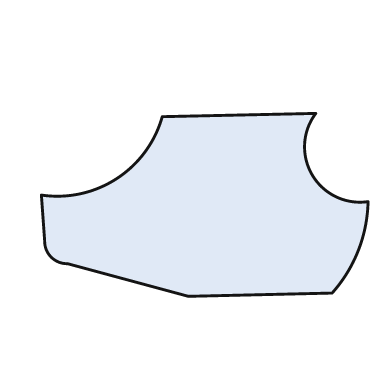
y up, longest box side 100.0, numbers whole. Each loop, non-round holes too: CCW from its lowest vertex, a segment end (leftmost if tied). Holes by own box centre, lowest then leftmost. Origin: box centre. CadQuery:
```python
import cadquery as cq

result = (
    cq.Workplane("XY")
    .moveTo(-5.0, -28.0)
    .lineTo(39.0, -27.0)
    .threePointArc((47.0, -14.0), (50.0, 1.0))
    .threePointArc((33.0, 9.0), (34.0, 28.0))
    .lineTo(-13.0, 27.0)
    .threePointArc((-27.0, 8.0), (-50.0, 3.0))
    .lineTo(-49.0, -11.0)
    .threePointArc((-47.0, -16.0), (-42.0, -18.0))
    .close()
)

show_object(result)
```